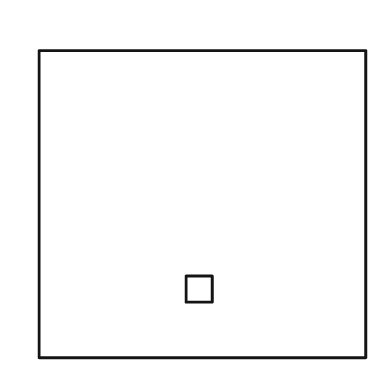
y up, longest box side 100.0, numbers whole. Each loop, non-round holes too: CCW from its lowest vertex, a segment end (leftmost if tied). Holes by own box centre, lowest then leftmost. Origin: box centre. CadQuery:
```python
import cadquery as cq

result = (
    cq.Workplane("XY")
    .moveTo(-50.0, -47.0)
    .lineTo(50.0, -47.0)
    .lineTo(50.0, 47.0)
    .lineTo(-50.0, 47.0)
    .close()
    .moveTo(-5.0, -30.0)
    .lineTo(3.0, -30.0)
    .lineTo(3.0, -22.0)
    .lineTo(-5.0, -22.0)
    .close()
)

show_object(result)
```